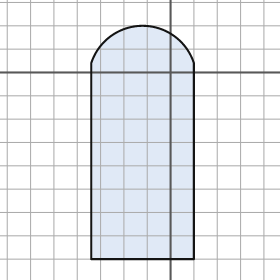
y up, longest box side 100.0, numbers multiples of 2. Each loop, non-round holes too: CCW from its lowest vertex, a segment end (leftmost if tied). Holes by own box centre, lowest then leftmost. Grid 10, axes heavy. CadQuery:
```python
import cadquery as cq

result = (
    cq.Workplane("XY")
    .moveTo(-34.0, -80.0)
    .lineTo(10.0, -80.0)
    .lineTo(10.0, 4.0)
    .threePointArc((-12.0, 20.0), (-34.0, 4.0))
    .close()
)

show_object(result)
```